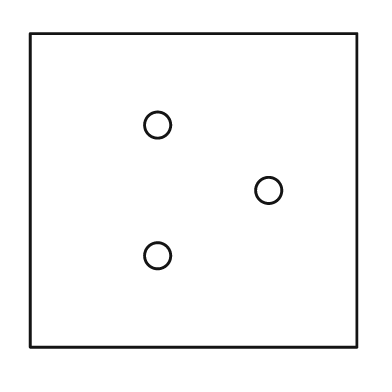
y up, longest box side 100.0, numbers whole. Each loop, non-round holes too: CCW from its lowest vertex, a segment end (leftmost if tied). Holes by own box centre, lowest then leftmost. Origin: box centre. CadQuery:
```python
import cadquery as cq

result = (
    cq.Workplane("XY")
    .moveTo(-50.0, -48.0)
    .lineTo(50.0, -48.0)
    .lineTo(50.0, 48.0)
    .lineTo(-50.0, 48.0)
    .close()
    .moveTo(-11.0, -20.0)
    .circle(4.0)
    .moveTo(23.0, 0.0)
    .circle(4.0)
    .moveTo(-11.0, 20.0)
    .circle(4.0)
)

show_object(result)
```